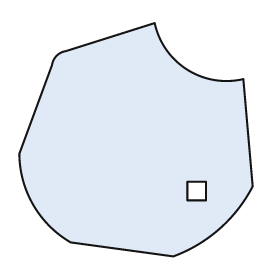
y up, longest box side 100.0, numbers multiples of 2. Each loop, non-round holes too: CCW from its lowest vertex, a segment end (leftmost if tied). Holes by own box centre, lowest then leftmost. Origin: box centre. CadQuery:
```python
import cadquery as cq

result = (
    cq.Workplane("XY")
    .moveTo(16.0, -50.0)
    .threePointArc((36.0, -38.0), (50.0, -20.0))
    .lineTo(46.0, 26.0)
    .threePointArc((22.0, 30.0), (8.0, 50.0))
    .lineTo(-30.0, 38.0)
    .threePointArc((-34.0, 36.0), (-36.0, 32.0))
    .lineTo(-50.0, -6.0)
    .threePointArc((-44.0, -28.0), (-28.0, -44.0))
    .close()
    .moveTo(22.0, -26.0)
    .lineTo(30.0, -26.0)
    .lineTo(30.0, -18.0)
    .lineTo(22.0, -18.0)
    .close()
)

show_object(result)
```